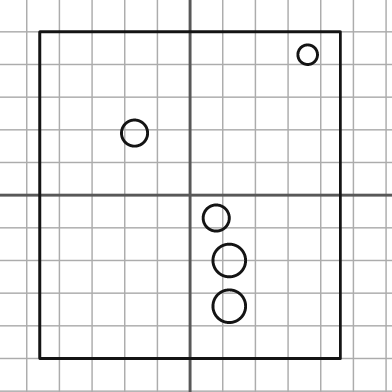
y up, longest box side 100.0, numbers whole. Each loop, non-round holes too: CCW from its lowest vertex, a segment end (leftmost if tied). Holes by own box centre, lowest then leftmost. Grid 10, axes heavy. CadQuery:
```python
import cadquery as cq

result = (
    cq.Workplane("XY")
    .moveTo(-46.0, -50.0)
    .lineTo(46.0, -50.0)
    .lineTo(46.0, 50.0)
    .lineTo(-46.0, 50.0)
    .close()
    .moveTo(12.0, -34.0)
    .circle(5.0)
    .moveTo(12.0, -20.0)
    .circle(5.0)
    .moveTo(8.0, -7.0)
    .circle(4.0)
    .moveTo(-17.0, 19.0)
    .circle(4.0)
    .moveTo(36.0, 43.0)
    .circle(3.0)
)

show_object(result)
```